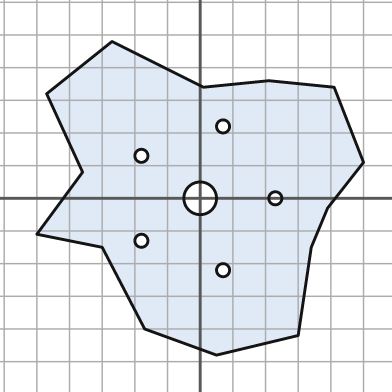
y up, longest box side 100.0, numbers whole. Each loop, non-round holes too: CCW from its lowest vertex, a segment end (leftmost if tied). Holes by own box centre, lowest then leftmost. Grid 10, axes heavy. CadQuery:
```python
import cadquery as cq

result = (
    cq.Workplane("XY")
    .moveTo(5.0, -48.0)
    .lineTo(30.0, -42.0)
    .lineTo(34.0, -15.0)
    .lineTo(39.0, -3.0)
    .lineTo(50.0, 11.0)
    .lineTo(41.0, 34.0)
    .lineTo(21.0, 36.0)
    .lineTo(1.0, 34.0)
    .lineTo(-27.0, 48.0)
    .lineTo(-47.0, 32.0)
    .lineTo(-36.0, 8.0)
    .lineTo(-50.0, -11.0)
    .lineTo(-30.0, -15.0)
    .lineTo(-17.0, -40.0)
    .close()
    .moveTo(7.0, -22.0)
    .circle(2.0)
    .moveTo(-18.0, -13.0)
    .circle(2.0)
    .moveTo(0.0, 0.0)
    .circle(5.0)
    .moveTo(23.0, 0.0)
    .circle(2.0)
    .moveTo(-18.0, 13.0)
    .circle(2.0)
    .moveTo(7.0, 22.0)
    .circle(2.0)
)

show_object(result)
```